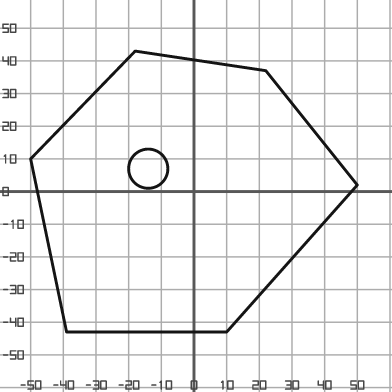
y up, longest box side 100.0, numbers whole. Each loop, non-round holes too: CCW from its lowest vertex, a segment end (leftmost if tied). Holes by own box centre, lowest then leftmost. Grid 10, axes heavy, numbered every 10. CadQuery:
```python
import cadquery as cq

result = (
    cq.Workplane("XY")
    .moveTo(-39.0, -43.0)
    .lineTo(10.0, -43.0)
    .lineTo(50.0, 2.0)
    .lineTo(22.0, 37.0)
    .lineTo(-18.0, 43.0)
    .lineTo(-50.0, 10.0)
    .close()
    .moveTo(-14.0, 7.0)
    .circle(6.0)
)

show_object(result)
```